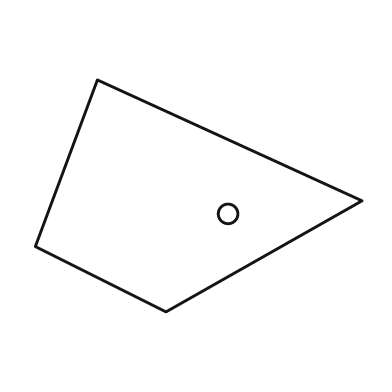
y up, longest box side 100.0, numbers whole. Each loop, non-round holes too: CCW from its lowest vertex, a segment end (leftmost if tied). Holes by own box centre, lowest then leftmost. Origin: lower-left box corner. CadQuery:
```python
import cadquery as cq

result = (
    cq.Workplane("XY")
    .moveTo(40.0, 0.0)
    .lineTo(100.0, 34.0)
    .lineTo(19.0, 71.0)
    .lineTo(0.0, 20.0)
    .close()
    .moveTo(59.0, 30.0)
    .circle(3.0)
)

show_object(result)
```